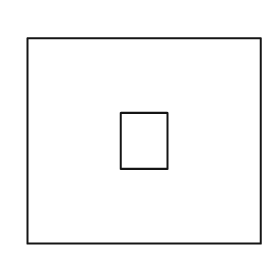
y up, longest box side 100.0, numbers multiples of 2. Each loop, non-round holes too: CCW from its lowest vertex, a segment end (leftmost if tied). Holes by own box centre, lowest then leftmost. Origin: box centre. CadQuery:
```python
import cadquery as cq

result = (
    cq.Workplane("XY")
    .moveTo(-50.0, -44.0)
    .lineTo(50.0, -44.0)
    .lineTo(50.0, 44.0)
    .lineTo(-50.0, 44.0)
    .close()
    .moveTo(-10.0, -12.0)
    .lineTo(10.0, -12.0)
    .lineTo(10.0, 12.0)
    .lineTo(-10.0, 12.0)
    .close()
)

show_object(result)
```